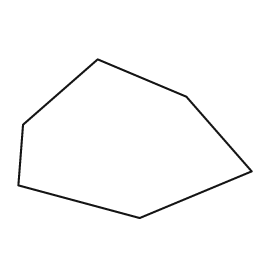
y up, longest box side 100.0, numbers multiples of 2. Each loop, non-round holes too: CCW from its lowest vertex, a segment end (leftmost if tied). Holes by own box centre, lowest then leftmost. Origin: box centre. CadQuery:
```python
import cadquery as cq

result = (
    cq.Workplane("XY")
    .moveTo(2.0, -34.0)
    .lineTo(50.0, -14.0)
    .lineTo(22.0, 18.0)
    .lineTo(-16.0, 34.0)
    .lineTo(-48.0, 6.0)
    .lineTo(-50.0, -20.0)
    .close()
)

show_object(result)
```